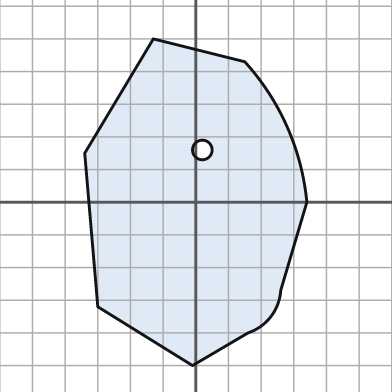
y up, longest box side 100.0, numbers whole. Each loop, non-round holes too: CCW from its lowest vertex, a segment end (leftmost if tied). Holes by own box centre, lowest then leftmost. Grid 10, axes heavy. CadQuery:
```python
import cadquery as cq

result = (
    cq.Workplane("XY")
    .moveTo(-1.0, -50.0)
    .lineTo(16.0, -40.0)
    .threePointArc((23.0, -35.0), (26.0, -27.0))
    .lineTo(34.0, 0.0)
    .threePointArc((28.0, 23.0), (15.0, 43.0))
    .lineTo(-13.0, 50.0)
    .lineTo(-34.0, 15.0)
    .lineTo(-30.0, -32.0)
    .close()
    .moveTo(2.0, 16.0)
    .circle(3.0)
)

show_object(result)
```